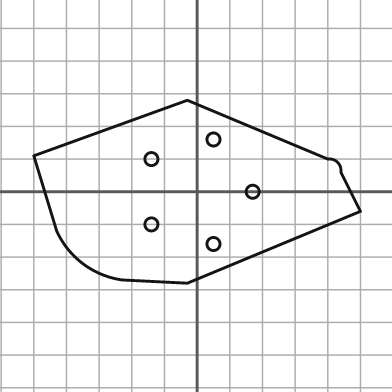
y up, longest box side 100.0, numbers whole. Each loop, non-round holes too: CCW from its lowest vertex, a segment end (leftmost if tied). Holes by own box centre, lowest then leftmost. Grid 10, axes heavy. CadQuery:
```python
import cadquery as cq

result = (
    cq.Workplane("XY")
    .moveTo(-3.0, -28.0)
    .lineTo(50.0, -6.0)
    .lineTo(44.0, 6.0)
    .threePointArc((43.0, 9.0), (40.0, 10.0))
    .lineTo(-3.0, 28.0)
    .lineTo(-50.0, 11.0)
    .lineTo(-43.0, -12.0)
    .threePointArc((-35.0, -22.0), (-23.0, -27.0))
    .close()
    .moveTo(5.0, -16.0)
    .circle(2.0)
    .moveTo(-14.0, -10.0)
    .circle(2.0)
    .moveTo(17.0, 0.0)
    .circle(2.0)
    .moveTo(-14.0, 10.0)
    .circle(2.0)
    .moveTo(5.0, 16.0)
    .circle(2.0)
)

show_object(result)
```